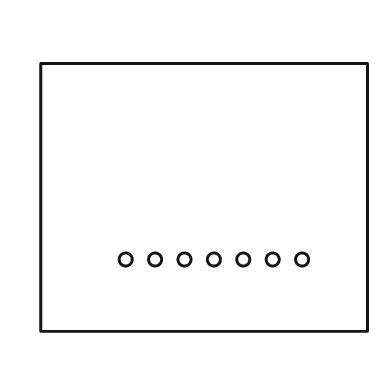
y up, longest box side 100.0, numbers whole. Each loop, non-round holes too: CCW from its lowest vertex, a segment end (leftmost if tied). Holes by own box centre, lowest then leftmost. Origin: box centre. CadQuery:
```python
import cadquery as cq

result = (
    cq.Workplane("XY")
    .moveTo(-50.0, -41.0)
    .lineTo(50.0, -41.0)
    .lineTo(50.0, 41.0)
    .lineTo(-50.0, 41.0)
    .close()
    .moveTo(-24.0, -19.0)
    .circle(2.0)
    .moveTo(-15.0, -19.0)
    .circle(2.0)
    .moveTo(-6.0, -19.0)
    .circle(2.0)
    .moveTo(3.0, -19.0)
    .circle(2.0)
    .moveTo(12.0, -19.0)
    .circle(2.0)
    .moveTo(21.0, -19.0)
    .circle(2.0)
    .moveTo(30.0, -19.0)
    .circle(2.0)
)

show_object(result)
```